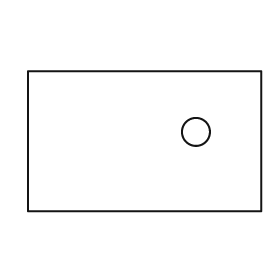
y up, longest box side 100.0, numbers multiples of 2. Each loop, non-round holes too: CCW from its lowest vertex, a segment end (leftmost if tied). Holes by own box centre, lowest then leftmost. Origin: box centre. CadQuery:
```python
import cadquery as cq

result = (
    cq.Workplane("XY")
    .moveTo(-50.0, -30.0)
    .lineTo(50.0, -30.0)
    .lineTo(50.0, 30.0)
    .lineTo(-50.0, 30.0)
    .close()
    .moveTo(22.0, 4.0)
    .circle(6.0)
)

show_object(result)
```